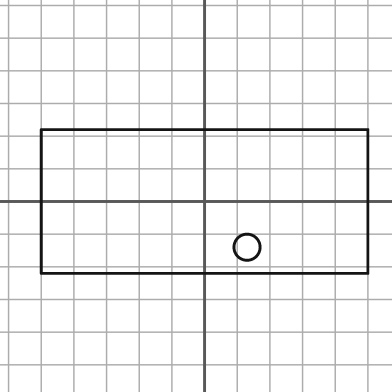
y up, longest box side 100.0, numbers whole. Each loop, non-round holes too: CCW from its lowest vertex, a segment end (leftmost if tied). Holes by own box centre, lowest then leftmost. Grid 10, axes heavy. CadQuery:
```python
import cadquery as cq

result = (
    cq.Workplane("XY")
    .moveTo(-50.0, -22.0)
    .lineTo(50.0, -22.0)
    .lineTo(50.0, 22.0)
    .lineTo(-50.0, 22.0)
    .close()
    .moveTo(13.0, -14.0)
    .circle(4.0)
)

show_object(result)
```